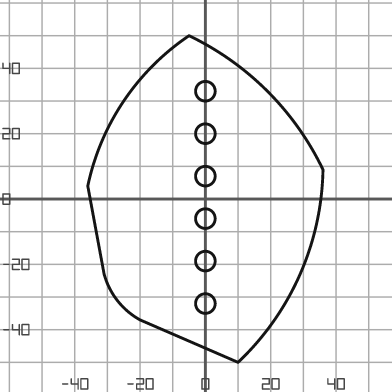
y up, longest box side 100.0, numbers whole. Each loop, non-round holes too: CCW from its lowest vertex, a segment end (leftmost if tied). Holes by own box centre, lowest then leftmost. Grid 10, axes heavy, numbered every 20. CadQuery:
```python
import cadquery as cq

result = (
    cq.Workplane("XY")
    .moveTo(10.0, -50.0)
    .threePointArc((29.0, -23.0), (36.0, 9.0))
    .threePointArc((19.0, 33.0), (-5.0, 50.0))
    .threePointArc((-25.0, 30.0), (-36.0, 4.0))
    .lineTo(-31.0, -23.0)
    .threePointArc((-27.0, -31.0), (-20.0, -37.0))
    .close()
    .moveTo(0.0, -32.0)
    .circle(3.0)
    .moveTo(0.0, -19.0)
    .circle(3.0)
    .moveTo(0.0, -6.0)
    .circle(3.0)
    .moveTo(0.0, 7.0)
    .circle(3.0)
    .moveTo(0.0, 20.0)
    .circle(3.0)
    .moveTo(0.0, 33.0)
    .circle(3.0)
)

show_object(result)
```